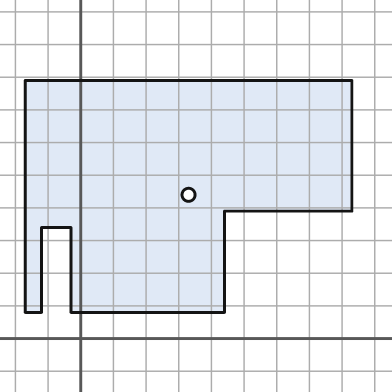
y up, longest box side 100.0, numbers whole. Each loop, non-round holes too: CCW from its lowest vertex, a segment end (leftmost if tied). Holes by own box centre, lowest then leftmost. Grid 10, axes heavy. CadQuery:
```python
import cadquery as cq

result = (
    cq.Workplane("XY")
    .moveTo(-17.0, 8.0)
    .lineTo(-12.0, 8.0)
    .lineTo(-12.0, 34.0)
    .lineTo(-3.0, 34.0)
    .lineTo(-3.0, 8.0)
    .lineTo(44.0, 8.0)
    .lineTo(44.0, 39.0)
    .lineTo(83.0, 39.0)
    .lineTo(83.0, 79.0)
    .lineTo(-17.0, 79.0)
    .close()
    .moveTo(33.0, 44.0)
    .circle(2.0)
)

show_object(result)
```